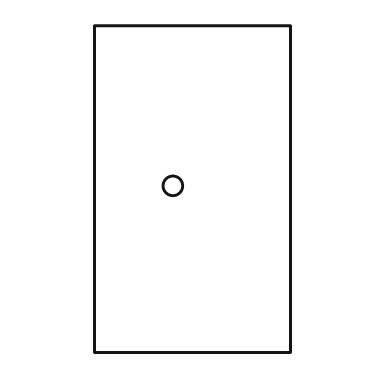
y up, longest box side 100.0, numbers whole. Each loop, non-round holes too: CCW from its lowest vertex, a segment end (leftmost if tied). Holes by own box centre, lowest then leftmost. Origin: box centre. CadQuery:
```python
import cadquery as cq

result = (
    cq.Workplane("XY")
    .moveTo(-30.0, -50.0)
    .lineTo(30.0, -50.0)
    .lineTo(30.0, 50.0)
    .lineTo(-30.0, 50.0)
    .close()
    .moveTo(-6.0, 1.0)
    .circle(3.0)
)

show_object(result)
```